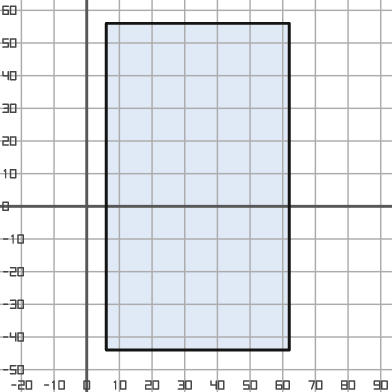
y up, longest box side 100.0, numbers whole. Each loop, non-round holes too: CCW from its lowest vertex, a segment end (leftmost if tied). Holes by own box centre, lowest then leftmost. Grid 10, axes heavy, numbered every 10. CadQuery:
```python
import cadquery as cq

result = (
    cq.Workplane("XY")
    .moveTo(6.0, -44.0)
    .lineTo(62.0, -44.0)
    .lineTo(62.0, 56.0)
    .lineTo(6.0, 56.0)
    .close()
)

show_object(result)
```